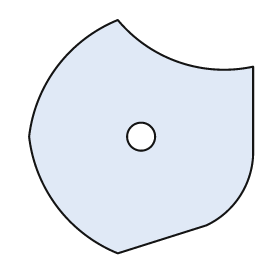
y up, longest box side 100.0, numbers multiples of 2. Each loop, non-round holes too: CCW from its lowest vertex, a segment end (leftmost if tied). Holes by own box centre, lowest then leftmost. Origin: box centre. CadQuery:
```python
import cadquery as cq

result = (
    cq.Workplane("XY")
    .moveTo(-10.0, -50.0)
    .lineTo(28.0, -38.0)
    .threePointArc((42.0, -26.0), (48.0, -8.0))
    .lineTo(48.0, 30.0)
    .threePointArc((16.0, 32.0), (-10.0, 50.0))
    .threePointArc((-36.0, 30.0), (-48.0, 0.0))
    .threePointArc((-36.0, -30.0), (-10.0, -50.0))
    .close()
    .moveTo(0.0, 0.0)
    .circle(6.0)
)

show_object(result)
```